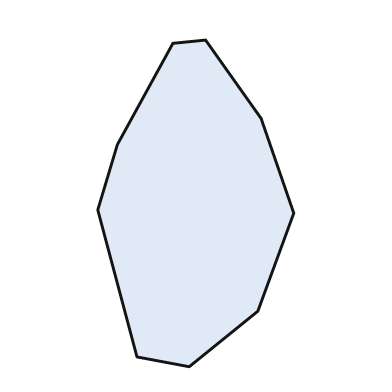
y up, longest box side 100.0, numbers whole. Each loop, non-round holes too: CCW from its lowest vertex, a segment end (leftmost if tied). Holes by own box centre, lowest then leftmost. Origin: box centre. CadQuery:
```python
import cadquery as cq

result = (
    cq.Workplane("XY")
    .moveTo(-2.0, -50.0)
    .lineTo(19.0, -33.0)
    .lineTo(30.0, -3.0)
    .lineTo(20.0, 26.0)
    .lineTo(3.0, 50.0)
    .lineTo(-7.0, 49.0)
    .lineTo(-24.0, 18.0)
    .lineTo(-30.0, -2.0)
    .lineTo(-18.0, -47.0)
    .close()
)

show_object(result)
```